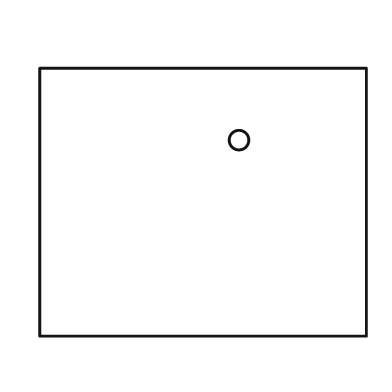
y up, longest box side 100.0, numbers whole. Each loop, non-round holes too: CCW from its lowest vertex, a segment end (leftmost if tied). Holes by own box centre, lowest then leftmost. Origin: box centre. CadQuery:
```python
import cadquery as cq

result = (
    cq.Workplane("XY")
    .moveTo(-50.0, -41.0)
    .lineTo(50.0, -41.0)
    .lineTo(50.0, 41.0)
    .lineTo(-50.0, 41.0)
    .close()
    .moveTo(11.0, 19.0)
    .circle(3.0)
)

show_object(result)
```